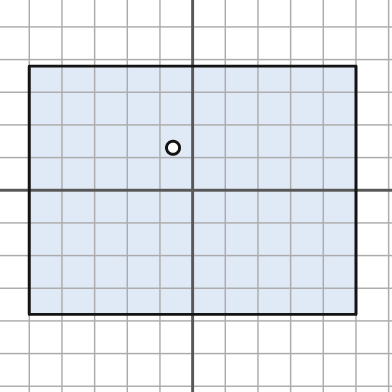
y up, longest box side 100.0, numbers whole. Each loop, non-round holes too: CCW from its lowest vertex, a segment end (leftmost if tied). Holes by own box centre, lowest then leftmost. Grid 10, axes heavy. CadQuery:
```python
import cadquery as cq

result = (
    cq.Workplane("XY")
    .moveTo(-50.0, -38.0)
    .lineTo(50.0, -38.0)
    .lineTo(50.0, 38.0)
    .lineTo(-50.0, 38.0)
    .close()
    .moveTo(-6.0, 13.0)
    .circle(2.0)
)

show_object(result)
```